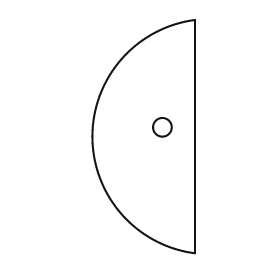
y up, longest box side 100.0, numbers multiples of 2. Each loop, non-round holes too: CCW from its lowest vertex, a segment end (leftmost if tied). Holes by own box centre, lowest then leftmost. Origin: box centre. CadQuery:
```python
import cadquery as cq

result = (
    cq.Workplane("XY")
    .moveTo(22.0, -50.0)
    .lineTo(22.0, 50.0)
    .threePointArc((-22.0, 0.0), (22.0, -50.0))
    .close()
    .moveTo(8.0, 4.0)
    .circle(4.0)
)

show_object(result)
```